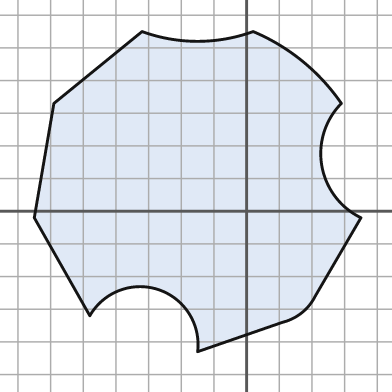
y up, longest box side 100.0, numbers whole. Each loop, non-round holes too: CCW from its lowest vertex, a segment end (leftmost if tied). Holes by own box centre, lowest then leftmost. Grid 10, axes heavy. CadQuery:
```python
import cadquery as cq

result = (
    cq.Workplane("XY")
    .moveTo(-15.0, -43.0)
    .lineTo(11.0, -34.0)
    .threePointArc((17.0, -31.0), (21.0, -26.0))
    .lineTo(35.0, -2.0)
    .threePointArc((23.0, 14.0), (29.0, 33.0))
    .threePointArc((17.0, 46.0), (2.0, 55.0))
    .threePointArc((-15.0, 52.0), (-32.0, 55.0))
    .lineTo(-59.0, 33.0)
    .lineTo(-65.0, -2.0)
    .lineTo(-48.0, -32.0)
    .threePointArc((-27.0, -24.0), (-15.0, -43.0))
    .close()
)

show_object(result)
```